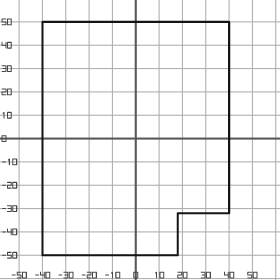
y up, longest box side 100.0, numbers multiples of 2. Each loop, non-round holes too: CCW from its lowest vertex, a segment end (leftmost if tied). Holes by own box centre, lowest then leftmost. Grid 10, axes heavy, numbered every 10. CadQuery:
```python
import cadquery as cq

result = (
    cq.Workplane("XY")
    .moveTo(-40.0, -50.0)
    .lineTo(18.0, -50.0)
    .lineTo(18.0, -32.0)
    .lineTo(40.0, -32.0)
    .lineTo(40.0, 50.0)
    .lineTo(-40.0, 50.0)
    .close()
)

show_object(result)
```